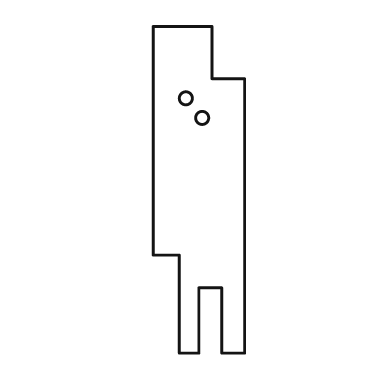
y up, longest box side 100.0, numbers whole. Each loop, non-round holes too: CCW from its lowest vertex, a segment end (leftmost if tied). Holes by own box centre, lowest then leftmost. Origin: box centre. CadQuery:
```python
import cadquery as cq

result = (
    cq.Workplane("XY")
    .moveTo(-6.0, -50.0)
    .lineTo(0.0, -50.0)
    .lineTo(0.0, -30.0)
    .lineTo(7.0, -30.0)
    .lineTo(7.0, -50.0)
    .lineTo(14.0, -50.0)
    .lineTo(14.0, 34.0)
    .lineTo(4.0, 34.0)
    .lineTo(4.0, 50.0)
    .lineTo(-14.0, 50.0)
    .lineTo(-14.0, -20.0)
    .lineTo(-6.0, -20.0)
    .close()
    .moveTo(1.0, 22.0)
    .circle(2.0)
    .moveTo(-4.0, 28.0)
    .circle(2.0)
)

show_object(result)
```